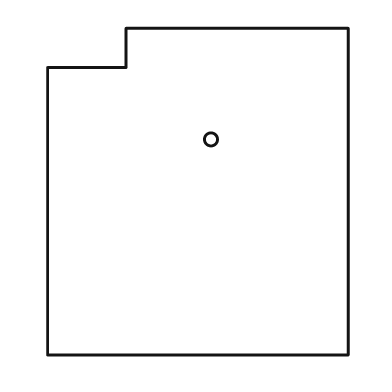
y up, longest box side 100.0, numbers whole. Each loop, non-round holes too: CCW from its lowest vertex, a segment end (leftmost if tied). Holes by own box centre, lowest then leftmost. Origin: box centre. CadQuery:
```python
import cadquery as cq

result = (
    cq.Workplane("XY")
    .moveTo(-46.0, -50.0)
    .lineTo(46.0, -50.0)
    .lineTo(46.0, 50.0)
    .lineTo(-22.0, 50.0)
    .lineTo(-22.0, 38.0)
    .lineTo(-46.0, 38.0)
    .close()
    .moveTo(4.0, 16.0)
    .circle(2.0)
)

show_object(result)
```